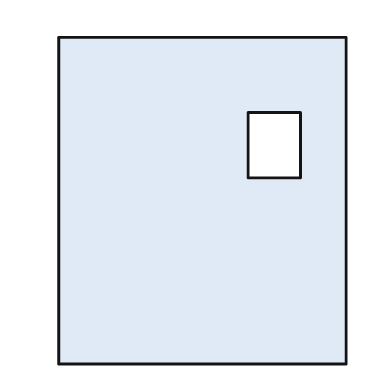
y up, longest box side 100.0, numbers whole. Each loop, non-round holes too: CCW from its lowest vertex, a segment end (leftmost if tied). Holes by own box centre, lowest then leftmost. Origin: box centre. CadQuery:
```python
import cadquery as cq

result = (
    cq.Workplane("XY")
    .moveTo(-44.0, -50.0)
    .lineTo(44.0, -50.0)
    .lineTo(44.0, 50.0)
    .lineTo(-44.0, 50.0)
    .close()
    .moveTo(14.0, 7.0)
    .lineTo(30.0, 7.0)
    .lineTo(30.0, 27.0)
    .lineTo(14.0, 27.0)
    .close()
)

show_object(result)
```